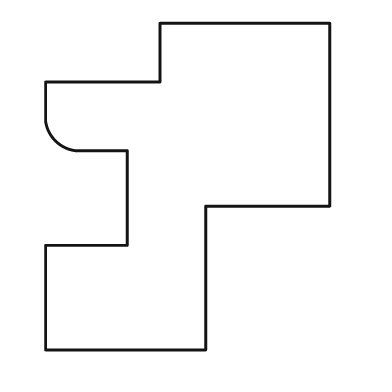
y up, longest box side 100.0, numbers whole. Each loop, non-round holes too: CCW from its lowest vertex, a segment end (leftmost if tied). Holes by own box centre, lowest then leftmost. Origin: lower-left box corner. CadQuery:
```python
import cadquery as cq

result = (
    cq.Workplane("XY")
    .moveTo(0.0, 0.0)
    .lineTo(49.0, 0.0)
    .lineTo(49.0, 44.0)
    .lineTo(87.0, 44.0)
    .lineTo(87.0, 100.0)
    .lineTo(35.0, 100.0)
    .lineTo(35.0, 82.0)
    .lineTo(0.0, 82.0)
    .lineTo(0.0, 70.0)
    .threePointArc((3.0, 64.0), (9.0, 61.0))
    .lineTo(25.0, 61.0)
    .lineTo(25.0, 32.0)
    .lineTo(0.0, 32.0)
    .close()
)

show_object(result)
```